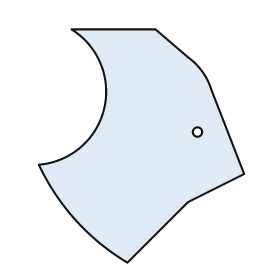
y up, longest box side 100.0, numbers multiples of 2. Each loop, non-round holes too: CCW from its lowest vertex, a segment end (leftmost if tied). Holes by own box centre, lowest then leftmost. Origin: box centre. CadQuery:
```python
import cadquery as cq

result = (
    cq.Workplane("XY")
    .moveTo(-6.0, -50.0)
    .lineTo(20.0, -24.0)
    .lineTo(44.0, -12.0)
    .lineTo(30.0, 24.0)
    .threePointArc((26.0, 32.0), (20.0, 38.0))
    .lineTo(6.0, 50.0)
    .lineTo(-30.0, 50.0)
    .threePointArc((-16.0, 16.0), (-44.0, -8.0))
    .threePointArc((-28.0, -32.0), (-6.0, -50.0))
    .close()
    .moveTo(24.0, 6.0)
    .circle(2.0)
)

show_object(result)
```